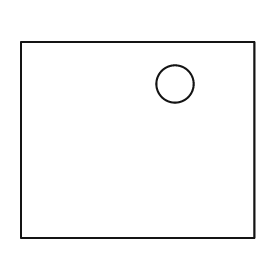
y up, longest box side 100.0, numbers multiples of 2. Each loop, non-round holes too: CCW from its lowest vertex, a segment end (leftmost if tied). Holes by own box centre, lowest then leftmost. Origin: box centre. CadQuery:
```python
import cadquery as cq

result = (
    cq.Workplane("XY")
    .moveTo(-50.0, -42.0)
    .lineTo(50.0, -42.0)
    .lineTo(50.0, 42.0)
    .lineTo(-50.0, 42.0)
    .close()
    .moveTo(16.0, 24.0)
    .circle(8.0)
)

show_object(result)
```